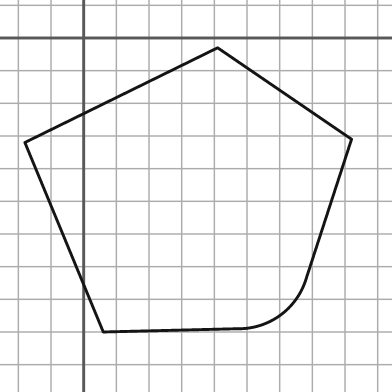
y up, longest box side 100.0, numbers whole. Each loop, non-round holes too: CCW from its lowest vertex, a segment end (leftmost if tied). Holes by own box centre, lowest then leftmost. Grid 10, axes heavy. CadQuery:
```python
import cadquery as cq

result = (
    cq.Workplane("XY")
    .moveTo(6.0, -90.0)
    .lineTo(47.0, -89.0)
    .threePointArc((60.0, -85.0), (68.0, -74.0))
    .lineTo(82.0, -31.0)
    .lineTo(41.0, -3.0)
    .lineTo(-18.0, -32.0)
    .close()
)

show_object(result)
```